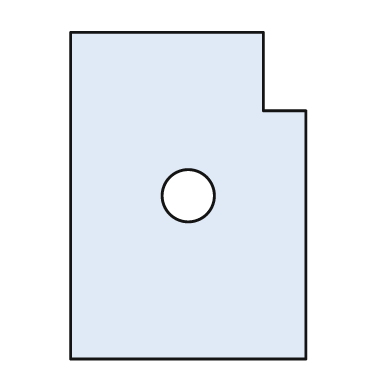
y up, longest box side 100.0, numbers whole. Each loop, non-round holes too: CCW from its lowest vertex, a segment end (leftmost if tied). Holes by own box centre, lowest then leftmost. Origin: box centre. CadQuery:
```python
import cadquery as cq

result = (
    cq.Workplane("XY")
    .moveTo(-36.0, -50.0)
    .lineTo(36.0, -50.0)
    .lineTo(36.0, 26.0)
    .lineTo(23.0, 26.0)
    .lineTo(23.0, 50.0)
    .lineTo(-36.0, 50.0)
    .close()
    .moveTo(0.0, 0.0)
    .circle(8.0)
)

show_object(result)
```